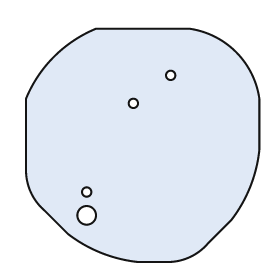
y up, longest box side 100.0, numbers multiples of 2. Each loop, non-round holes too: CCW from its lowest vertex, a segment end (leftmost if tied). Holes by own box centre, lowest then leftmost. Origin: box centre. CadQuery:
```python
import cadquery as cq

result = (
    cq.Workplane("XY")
    .moveTo(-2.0, -50.0)
    .lineTo(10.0, -50.0)
    .threePointArc((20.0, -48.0), (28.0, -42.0))
    .lineTo(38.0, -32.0)
    .threePointArc((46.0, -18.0), (50.0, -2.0))
    .lineTo(50.0, 20.0)
    .threePointArc((40.0, 40.0), (20.0, 50.0))
    .lineTo(-20.0, 50.0)
    .threePointArc((-38.0, 38.0), (-50.0, 20.0))
    .lineTo(-50.0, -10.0)
    .threePointArc((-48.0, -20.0), (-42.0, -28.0))
    .lineTo(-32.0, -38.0)
    .threePointArc((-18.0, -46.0), (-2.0, -50.0))
    .close()
    .moveTo(-24.0, -30.0)
    .circle(4.0)
    .moveTo(-24.0, -20.0)
    .circle(2.0)
    .moveTo(-4.0, 18.0)
    .circle(2.0)
    .moveTo(12.0, 30.0)
    .circle(2.0)
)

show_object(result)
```